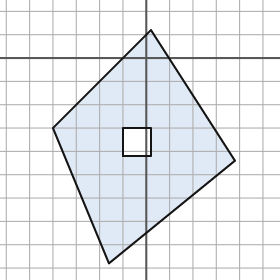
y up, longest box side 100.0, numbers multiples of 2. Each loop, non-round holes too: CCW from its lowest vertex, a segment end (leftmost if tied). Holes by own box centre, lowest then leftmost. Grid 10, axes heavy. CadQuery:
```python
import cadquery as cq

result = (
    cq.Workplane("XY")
    .moveTo(-16.0, -88.0)
    .lineTo(38.0, -44.0)
    .lineTo(2.0, 12.0)
    .lineTo(-40.0, -30.0)
    .close()
    .moveTo(-10.0, -42.0)
    .lineTo(2.0, -42.0)
    .lineTo(2.0, -30.0)
    .lineTo(-10.0, -30.0)
    .close()
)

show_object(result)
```